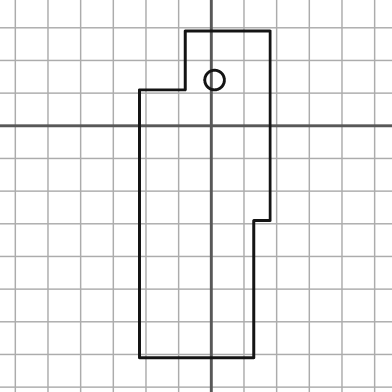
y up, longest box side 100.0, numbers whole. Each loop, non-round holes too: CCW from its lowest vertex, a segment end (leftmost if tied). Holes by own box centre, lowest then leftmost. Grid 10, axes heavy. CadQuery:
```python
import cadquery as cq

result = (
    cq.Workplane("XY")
    .moveTo(-22.0, -71.0)
    .lineTo(13.0, -71.0)
    .lineTo(13.0, -29.0)
    .lineTo(18.0, -29.0)
    .lineTo(18.0, 29.0)
    .lineTo(-8.0, 29.0)
    .lineTo(-8.0, 11.0)
    .lineTo(-22.0, 11.0)
    .close()
    .moveTo(1.0, 14.0)
    .circle(3.0)
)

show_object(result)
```